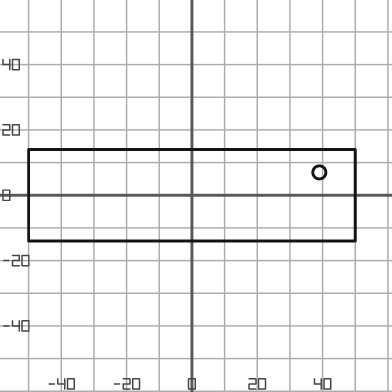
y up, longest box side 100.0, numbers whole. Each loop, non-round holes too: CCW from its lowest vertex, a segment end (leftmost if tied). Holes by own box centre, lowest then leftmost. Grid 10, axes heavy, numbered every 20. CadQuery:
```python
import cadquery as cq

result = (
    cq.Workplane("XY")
    .moveTo(-50.0, -14.0)
    .lineTo(50.0, -14.0)
    .lineTo(50.0, 14.0)
    .lineTo(-50.0, 14.0)
    .close()
    .moveTo(39.0, 7.0)
    .circle(2.0)
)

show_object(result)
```